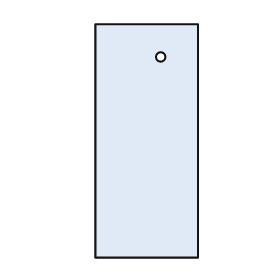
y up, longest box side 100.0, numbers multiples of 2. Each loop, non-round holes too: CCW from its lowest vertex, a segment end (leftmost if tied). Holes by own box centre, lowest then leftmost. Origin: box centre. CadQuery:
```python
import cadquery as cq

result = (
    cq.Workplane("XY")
    .moveTo(-22.0, -50.0)
    .lineTo(22.0, -50.0)
    .lineTo(22.0, 50.0)
    .lineTo(-22.0, 50.0)
    .close()
    .moveTo(6.0, 36.0)
    .circle(2.0)
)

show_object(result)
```